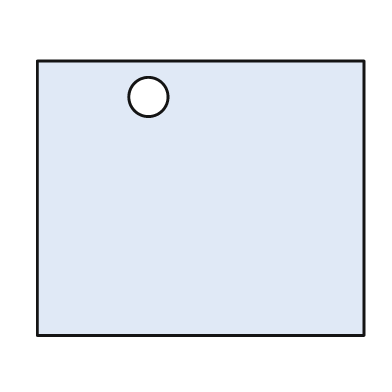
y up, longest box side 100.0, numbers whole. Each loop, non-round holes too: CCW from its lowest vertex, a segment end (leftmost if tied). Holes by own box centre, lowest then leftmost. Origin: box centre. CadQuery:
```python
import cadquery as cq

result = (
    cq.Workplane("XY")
    .moveTo(-50.0, -42.0)
    .lineTo(50.0, -42.0)
    .lineTo(50.0, 42.0)
    .lineTo(-50.0, 42.0)
    .close()
    .moveTo(-16.0, 31.0)
    .circle(6.0)
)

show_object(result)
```